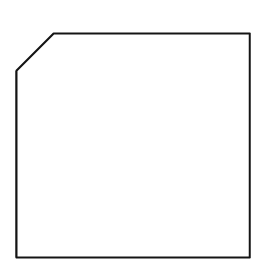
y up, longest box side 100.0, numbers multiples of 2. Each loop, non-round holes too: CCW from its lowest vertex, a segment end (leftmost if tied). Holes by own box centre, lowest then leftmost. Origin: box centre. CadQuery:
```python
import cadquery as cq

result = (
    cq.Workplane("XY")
    .moveTo(-50.0, -48.0)
    .lineTo(50.0, -48.0)
    .lineTo(50.0, 48.0)
    .lineTo(-34.0, 48.0)
    .lineTo(-50.0, 32.0)
    .close()
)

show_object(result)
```